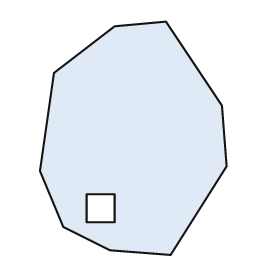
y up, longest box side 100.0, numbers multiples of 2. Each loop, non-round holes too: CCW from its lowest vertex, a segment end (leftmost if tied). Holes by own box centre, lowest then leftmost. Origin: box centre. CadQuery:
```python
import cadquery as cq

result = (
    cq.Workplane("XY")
    .moveTo(16.0, -50.0)
    .lineTo(40.0, -12.0)
    .lineTo(38.0, 14.0)
    .lineTo(14.0, 50.0)
    .lineTo(-8.0, 48.0)
    .lineTo(-34.0, 28.0)
    .lineTo(-40.0, -14.0)
    .lineTo(-30.0, -38.0)
    .lineTo(-10.0, -48.0)
    .close()
    .moveTo(-20.0, -36.0)
    .lineTo(-8.0, -36.0)
    .lineTo(-8.0, -24.0)
    .lineTo(-20.0, -24.0)
    .close()
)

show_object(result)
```